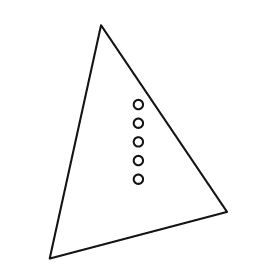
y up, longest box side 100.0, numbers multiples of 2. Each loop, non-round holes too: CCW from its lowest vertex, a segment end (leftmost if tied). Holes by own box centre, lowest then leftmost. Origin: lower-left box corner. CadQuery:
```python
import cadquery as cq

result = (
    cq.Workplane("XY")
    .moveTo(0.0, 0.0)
    .lineTo(76.0, 20.0)
    .lineTo(22.0, 100.0)
    .close()
    .moveTo(38.0, 34.0)
    .circle(2.0)
    .moveTo(38.0, 42.0)
    .circle(2.0)
    .moveTo(38.0, 50.0)
    .circle(2.0)
    .moveTo(38.0, 58.0)
    .circle(2.0)
    .moveTo(38.0, 66.0)
    .circle(2.0)
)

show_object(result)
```